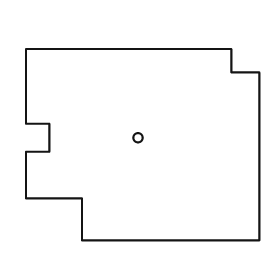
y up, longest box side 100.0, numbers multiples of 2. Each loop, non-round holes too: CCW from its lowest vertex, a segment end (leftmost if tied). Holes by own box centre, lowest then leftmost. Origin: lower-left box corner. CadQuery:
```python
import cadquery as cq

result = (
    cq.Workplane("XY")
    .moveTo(24.0, 0.0)
    .lineTo(100.0, 0.0)
    .lineTo(100.0, 72.0)
    .lineTo(88.0, 72.0)
    .lineTo(88.0, 82.0)
    .lineTo(0.0, 82.0)
    .lineTo(0.0, 50.0)
    .lineTo(10.0, 50.0)
    .lineTo(10.0, 38.0)
    .lineTo(0.0, 38.0)
    .lineTo(0.0, 18.0)
    .lineTo(24.0, 18.0)
    .close()
    .moveTo(48.0, 44.0)
    .circle(2.0)
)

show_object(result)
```